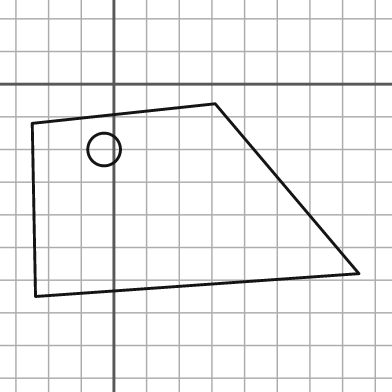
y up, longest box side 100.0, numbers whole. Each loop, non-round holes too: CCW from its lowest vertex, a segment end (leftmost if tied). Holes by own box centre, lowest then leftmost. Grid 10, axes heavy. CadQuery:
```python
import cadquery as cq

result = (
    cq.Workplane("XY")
    .moveTo(-24.0, -65.0)
    .lineTo(75.0, -58.0)
    .lineTo(31.0, -6.0)
    .lineTo(-25.0, -12.0)
    .close()
    .moveTo(-3.0, -20.0)
    .circle(5.0)
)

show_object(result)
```